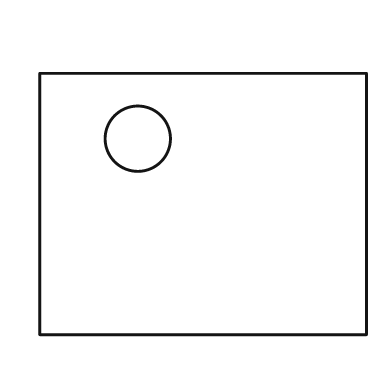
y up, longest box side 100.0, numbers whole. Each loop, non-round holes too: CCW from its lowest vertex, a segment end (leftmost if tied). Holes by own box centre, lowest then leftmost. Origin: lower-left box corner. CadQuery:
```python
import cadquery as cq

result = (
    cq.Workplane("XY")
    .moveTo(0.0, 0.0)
    .lineTo(100.0, 0.0)
    .lineTo(100.0, 80.0)
    .lineTo(0.0, 80.0)
    .close()
    .moveTo(30.0, 60.0)
    .circle(10.0)
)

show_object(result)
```